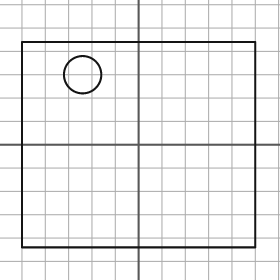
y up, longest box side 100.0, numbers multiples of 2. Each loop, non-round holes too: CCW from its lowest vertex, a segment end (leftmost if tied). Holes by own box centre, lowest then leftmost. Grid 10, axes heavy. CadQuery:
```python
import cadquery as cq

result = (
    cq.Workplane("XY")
    .moveTo(-50.0, -44.0)
    .lineTo(50.0, -44.0)
    .lineTo(50.0, 44.0)
    .lineTo(-50.0, 44.0)
    .close()
    .moveTo(-24.0, 30.0)
    .circle(8.0)
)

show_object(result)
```